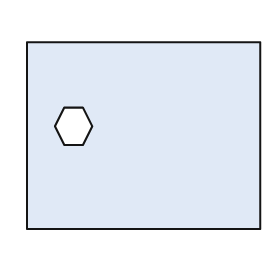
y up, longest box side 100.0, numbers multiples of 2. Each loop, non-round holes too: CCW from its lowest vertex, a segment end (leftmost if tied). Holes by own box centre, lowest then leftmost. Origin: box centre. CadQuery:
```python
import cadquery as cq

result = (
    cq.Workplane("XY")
    .moveTo(-50.0, -40.0)
    .lineTo(50.0, -40.0)
    .lineTo(50.0, 40.0)
    .lineTo(-50.0, 40.0)
    .close()
    .moveTo(-34.0, -4.0)
    .lineTo(-26.0, -4.0)
    .lineTo(-22.0, 4.0)
    .lineTo(-26.0, 12.0)
    .lineTo(-34.0, 12.0)
    .lineTo(-38.0, 4.0)
    .close()
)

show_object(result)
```